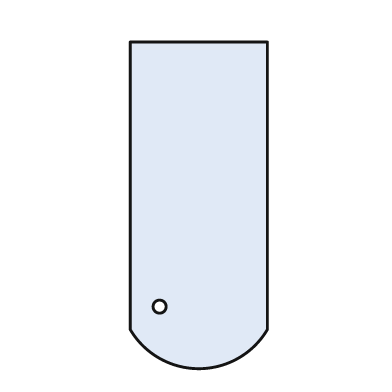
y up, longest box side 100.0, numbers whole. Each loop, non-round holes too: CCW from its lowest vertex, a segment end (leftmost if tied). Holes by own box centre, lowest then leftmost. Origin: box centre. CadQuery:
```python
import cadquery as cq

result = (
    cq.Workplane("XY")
    .moveTo(-21.0, -38.0)
    .threePointArc((0.0, -50.0), (21.0, -38.0))
    .lineTo(21.0, 50.0)
    .lineTo(-21.0, 50.0)
    .close()
    .moveTo(-12.0, -31.0)
    .circle(2.0)
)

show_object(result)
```